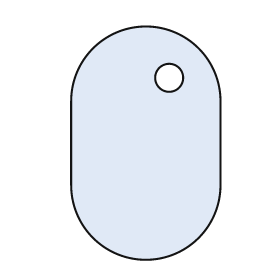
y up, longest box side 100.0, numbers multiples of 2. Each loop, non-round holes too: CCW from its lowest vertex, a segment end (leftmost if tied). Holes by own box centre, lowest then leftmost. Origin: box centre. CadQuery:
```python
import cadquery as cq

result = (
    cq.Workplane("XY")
    .moveTo(-32.0, -18.0)
    .threePointArc((0.0, -50.0), (32.0, -18.0))
    .lineTo(32.0, 18.0)
    .threePointArc((0.0, 50.0), (-32.0, 18.0))
    .close()
    .moveTo(10.0, 28.0)
    .circle(6.0)
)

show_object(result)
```